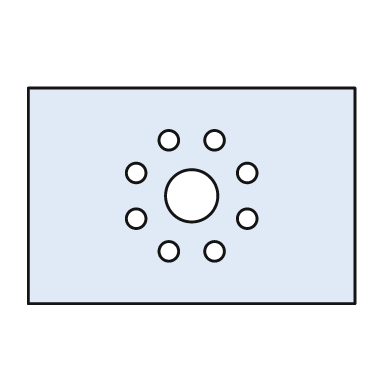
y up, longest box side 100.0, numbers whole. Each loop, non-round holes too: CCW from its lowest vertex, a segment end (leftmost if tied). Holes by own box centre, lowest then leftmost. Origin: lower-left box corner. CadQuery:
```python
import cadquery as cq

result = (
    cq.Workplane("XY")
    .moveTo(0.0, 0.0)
    .lineTo(100.0, 0.0)
    .lineTo(100.0, 66.0)
    .lineTo(0.0, 66.0)
    .close()
    .moveTo(43.0, 16.0)
    .circle(3.0)
    .moveTo(57.0, 16.0)
    .circle(3.0)
    .moveTo(33.0, 26.0)
    .circle(3.0)
    .moveTo(67.0, 26.0)
    .circle(3.0)
    .moveTo(50.0, 33.0)
    .circle(8.0)
    .moveTo(33.0, 40.0)
    .circle(3.0)
    .moveTo(67.0, 40.0)
    .circle(3.0)
    .moveTo(43.0, 50.0)
    .circle(3.0)
    .moveTo(57.0, 50.0)
    .circle(3.0)
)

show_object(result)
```